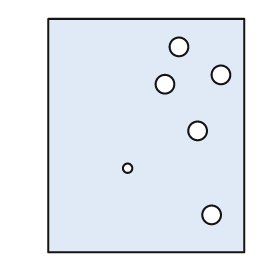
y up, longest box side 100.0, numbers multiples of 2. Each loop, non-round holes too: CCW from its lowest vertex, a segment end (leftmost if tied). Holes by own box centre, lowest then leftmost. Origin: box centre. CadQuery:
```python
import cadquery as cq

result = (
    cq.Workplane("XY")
    .moveTo(-42.0, -50.0)
    .lineTo(42.0, -50.0)
    .lineTo(42.0, 50.0)
    .lineTo(-42.0, 50.0)
    .close()
    .moveTo(28.0, -34.0)
    .circle(4.0)
    .moveTo(-8.0, -14.0)
    .circle(2.0)
    .moveTo(22.0, 2.0)
    .circle(4.0)
    .moveTo(8.0, 22.0)
    .circle(4.0)
    .moveTo(32.0, 26.0)
    .circle(4.0)
    .moveTo(14.0, 38.0)
    .circle(4.0)
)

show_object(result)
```